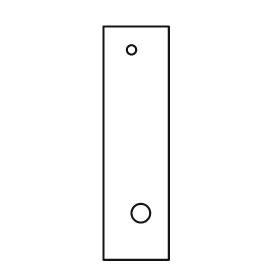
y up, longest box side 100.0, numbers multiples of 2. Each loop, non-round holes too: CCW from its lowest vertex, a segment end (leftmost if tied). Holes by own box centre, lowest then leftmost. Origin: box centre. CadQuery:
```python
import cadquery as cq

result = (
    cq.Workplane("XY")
    .moveTo(-14.0, -50.0)
    .lineTo(14.0, -50.0)
    .lineTo(14.0, 50.0)
    .lineTo(-14.0, 50.0)
    .close()
    .moveTo(2.0, -30.0)
    .circle(4.0)
    .moveTo(-2.0, 40.0)
    .circle(2.0)
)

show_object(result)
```